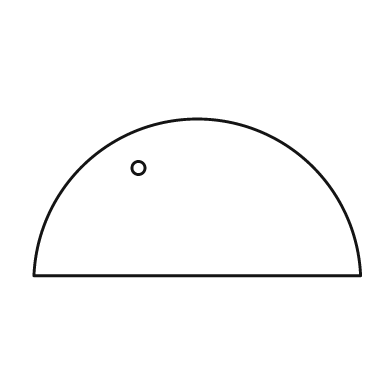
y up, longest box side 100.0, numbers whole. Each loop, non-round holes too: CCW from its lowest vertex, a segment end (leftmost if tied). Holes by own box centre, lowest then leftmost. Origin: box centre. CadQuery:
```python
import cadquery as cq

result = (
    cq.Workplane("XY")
    .moveTo(-50.0, -24.0)
    .lineTo(50.0, -24.0)
    .threePointArc((0.0, 24.0), (-50.0, -24.0))
    .close()
    .moveTo(-18.0, 9.0)
    .circle(2.0)
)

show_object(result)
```